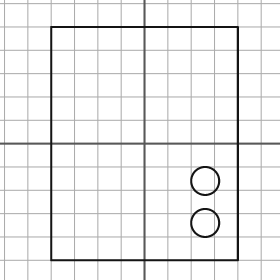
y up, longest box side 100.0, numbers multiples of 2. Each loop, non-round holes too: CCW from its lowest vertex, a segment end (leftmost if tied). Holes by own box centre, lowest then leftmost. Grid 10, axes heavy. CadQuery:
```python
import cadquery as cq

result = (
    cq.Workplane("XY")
    .moveTo(-40.0, -50.0)
    .lineTo(40.0, -50.0)
    .lineTo(40.0, 50.0)
    .lineTo(-40.0, 50.0)
    .close()
    .moveTo(26.0, -34.0)
    .circle(6.0)
    .moveTo(26.0, -16.0)
    .circle(6.0)
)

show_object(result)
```